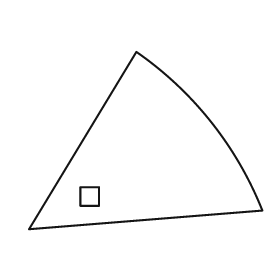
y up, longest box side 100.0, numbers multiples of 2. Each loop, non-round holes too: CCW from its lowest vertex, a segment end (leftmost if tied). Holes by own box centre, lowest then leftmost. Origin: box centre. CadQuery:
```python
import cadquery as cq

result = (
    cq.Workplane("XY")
    .moveTo(-50.0, -38.0)
    .lineTo(50.0, -30.0)
    .threePointArc((28.0, 8.0), (-4.0, 38.0))
    .close()
    .moveTo(-28.0, -28.0)
    .lineTo(-20.0, -28.0)
    .lineTo(-20.0, -20.0)
    .lineTo(-28.0, -20.0)
    .close()
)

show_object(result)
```